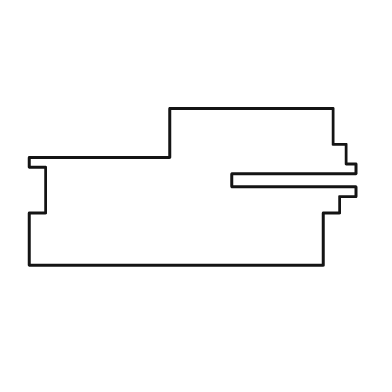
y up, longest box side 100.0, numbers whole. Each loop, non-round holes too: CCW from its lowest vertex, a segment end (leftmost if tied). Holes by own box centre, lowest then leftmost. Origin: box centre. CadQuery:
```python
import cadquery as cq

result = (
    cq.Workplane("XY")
    .moveTo(-50.0, -24.0)
    .lineTo(40.0, -24.0)
    .lineTo(40.0, -8.0)
    .lineTo(45.0, -8.0)
    .lineTo(45.0, -3.0)
    .lineTo(50.0, -3.0)
    .lineTo(50.0, 0.0)
    .lineTo(12.0, 0.0)
    .lineTo(12.0, 4.0)
    .lineTo(50.0, 4.0)
    .lineTo(50.0, 7.0)
    .lineTo(47.0, 7.0)
    .lineTo(47.0, 13.0)
    .lineTo(43.0, 13.0)
    .lineTo(43.0, 24.0)
    .lineTo(-7.0, 24.0)
    .lineTo(-7.0, 9.0)
    .lineTo(-50.0, 9.0)
    .lineTo(-50.0, 6.0)
    .lineTo(-45.0, 6.0)
    .lineTo(-45.0, -8.0)
    .lineTo(-50.0, -8.0)
    .close()
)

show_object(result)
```